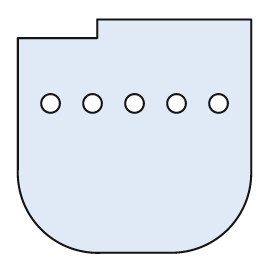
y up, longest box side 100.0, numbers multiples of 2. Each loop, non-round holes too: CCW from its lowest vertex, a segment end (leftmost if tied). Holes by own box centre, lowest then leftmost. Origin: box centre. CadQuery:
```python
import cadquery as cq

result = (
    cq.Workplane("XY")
    .moveTo(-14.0, -50.0)
    .lineTo(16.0, -50.0)
    .threePointArc((40.0, -40.0), (50.0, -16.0))
    .lineTo(50.0, 50.0)
    .lineTo(-16.0, 50.0)
    .lineTo(-16.0, 42.0)
    .lineTo(-50.0, 42.0)
    .lineTo(-50.0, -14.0)
    .threePointArc((-40.0, -40.0), (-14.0, -50.0))
    .close()
    .moveTo(-36.0, 14.0)
    .circle(4.0)
    .moveTo(-18.0, 14.0)
    .circle(4.0)
    .moveTo(0.0, 14.0)
    .circle(4.0)
    .moveTo(18.0, 14.0)
    .circle(4.0)
    .moveTo(36.0, 14.0)
    .circle(4.0)
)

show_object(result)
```